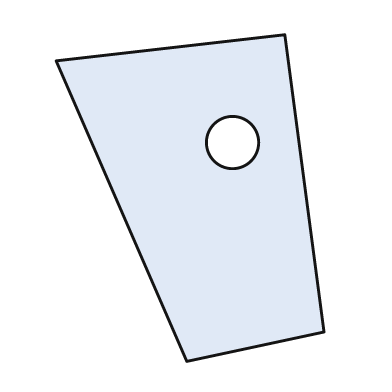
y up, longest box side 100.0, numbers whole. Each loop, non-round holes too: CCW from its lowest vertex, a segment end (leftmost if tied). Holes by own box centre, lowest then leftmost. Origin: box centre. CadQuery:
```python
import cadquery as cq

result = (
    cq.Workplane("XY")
    .moveTo(-1.0, -50.0)
    .lineTo(41.0, -41.0)
    .lineTo(29.0, 50.0)
    .lineTo(-41.0, 42.0)
    .close()
    .moveTo(13.0, 17.0)
    .circle(8.0)
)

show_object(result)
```